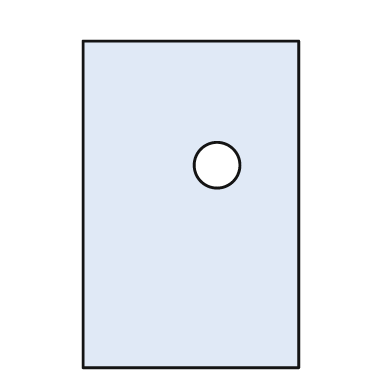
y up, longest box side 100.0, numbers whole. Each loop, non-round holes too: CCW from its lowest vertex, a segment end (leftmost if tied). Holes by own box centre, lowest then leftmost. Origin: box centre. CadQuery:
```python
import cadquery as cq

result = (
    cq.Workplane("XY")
    .moveTo(-33.0, -50.0)
    .lineTo(33.0, -50.0)
    .lineTo(33.0, 50.0)
    .lineTo(-33.0, 50.0)
    .close()
    .moveTo(8.0, 12.0)
    .circle(7.0)
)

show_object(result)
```